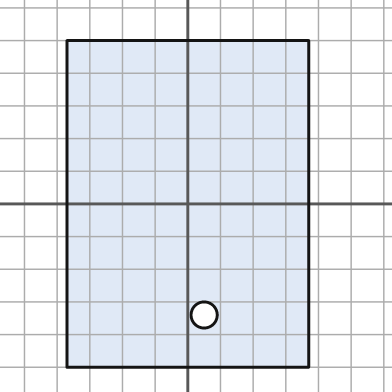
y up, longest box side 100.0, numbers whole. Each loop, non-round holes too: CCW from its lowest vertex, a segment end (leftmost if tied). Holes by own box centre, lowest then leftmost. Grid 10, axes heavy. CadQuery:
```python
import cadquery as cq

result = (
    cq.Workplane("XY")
    .moveTo(-37.0, -50.0)
    .lineTo(37.0, -50.0)
    .lineTo(37.0, 50.0)
    .lineTo(-37.0, 50.0)
    .close()
    .moveTo(5.0, -34.0)
    .circle(4.0)
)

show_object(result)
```